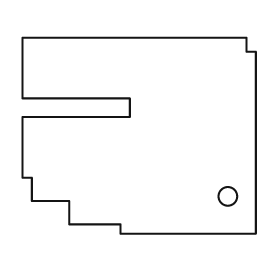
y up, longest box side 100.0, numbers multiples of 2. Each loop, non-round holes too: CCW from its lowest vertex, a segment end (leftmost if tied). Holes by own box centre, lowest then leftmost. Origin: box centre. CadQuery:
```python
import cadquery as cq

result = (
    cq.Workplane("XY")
    .moveTo(-8.0, -42.0)
    .lineTo(50.0, -42.0)
    .lineTo(50.0, 36.0)
    .lineTo(46.0, 36.0)
    .lineTo(46.0, 42.0)
    .lineTo(-50.0, 42.0)
    .lineTo(-50.0, 16.0)
    .lineTo(-4.0, 16.0)
    .lineTo(-4.0, 8.0)
    .lineTo(-50.0, 8.0)
    .lineTo(-50.0, -18.0)
    .lineTo(-46.0, -18.0)
    .lineTo(-46.0, -28.0)
    .lineTo(-30.0, -28.0)
    .lineTo(-30.0, -38.0)
    .lineTo(-8.0, -38.0)
    .close()
    .moveTo(38.0, -26.0)
    .circle(4.0)
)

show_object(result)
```